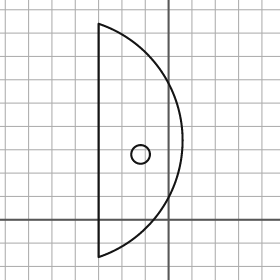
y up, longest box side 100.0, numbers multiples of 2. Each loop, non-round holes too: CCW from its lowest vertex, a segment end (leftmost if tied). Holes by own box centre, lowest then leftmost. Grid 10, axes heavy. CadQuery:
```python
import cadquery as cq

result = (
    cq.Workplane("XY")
    .moveTo(-30.0, -16.0)
    .threePointArc((6.0, 34.0), (-30.0, 84.0))
    .close()
    .moveTo(-12.0, 28.0)
    .circle(4.0)
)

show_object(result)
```